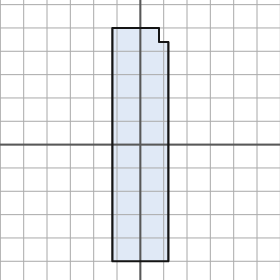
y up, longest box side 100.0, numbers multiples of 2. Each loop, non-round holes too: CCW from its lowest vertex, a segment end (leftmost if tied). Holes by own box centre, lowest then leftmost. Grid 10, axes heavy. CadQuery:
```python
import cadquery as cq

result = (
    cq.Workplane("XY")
    .moveTo(-12.0, -50.0)
    .lineTo(12.0, -50.0)
    .lineTo(12.0, 44.0)
    .lineTo(8.0, 44.0)
    .lineTo(8.0, 50.0)
    .lineTo(-12.0, 50.0)
    .close()
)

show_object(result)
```